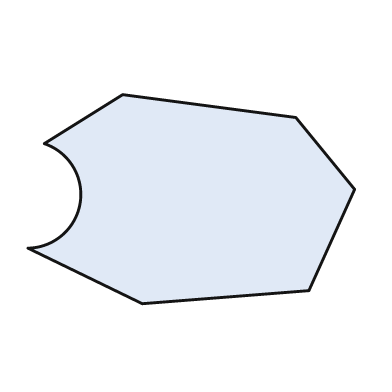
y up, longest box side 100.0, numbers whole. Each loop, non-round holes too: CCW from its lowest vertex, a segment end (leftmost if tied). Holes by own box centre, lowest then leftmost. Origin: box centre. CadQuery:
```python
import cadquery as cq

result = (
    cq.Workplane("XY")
    .moveTo(-15.0, -32.0)
    .lineTo(36.0, -28.0)
    .lineTo(50.0, 3.0)
    .lineTo(32.0, 25.0)
    .lineTo(-21.0, 32.0)
    .lineTo(-45.0, 17.0)
    .threePointArc((-34.0, -1.0), (-50.0, -15.0))
    .close()
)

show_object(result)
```